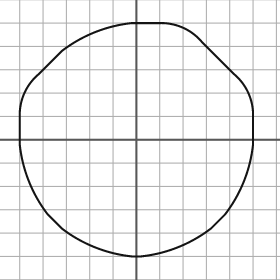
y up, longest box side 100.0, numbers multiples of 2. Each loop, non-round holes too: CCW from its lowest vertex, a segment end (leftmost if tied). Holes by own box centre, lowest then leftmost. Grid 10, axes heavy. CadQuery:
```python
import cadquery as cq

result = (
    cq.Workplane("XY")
    .moveTo(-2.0, -50.0)
    .lineTo(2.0, -50.0)
    .threePointArc((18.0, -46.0), (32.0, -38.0))
    .lineTo(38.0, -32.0)
    .threePointArc((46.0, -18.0), (50.0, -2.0))
    .lineTo(50.0, 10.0)
    .threePointArc((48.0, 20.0), (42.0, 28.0))
    .lineTo(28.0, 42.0)
    .threePointArc((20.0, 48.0), (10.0, 50.0))
    .lineTo(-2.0, 50.0)
    .threePointArc((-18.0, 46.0), (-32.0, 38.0))
    .lineTo(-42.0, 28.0)
    .threePointArc((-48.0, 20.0), (-50.0, 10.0))
    .lineTo(-50.0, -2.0)
    .threePointArc((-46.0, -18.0), (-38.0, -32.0))
    .lineTo(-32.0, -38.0)
    .threePointArc((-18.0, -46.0), (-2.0, -50.0))
    .close()
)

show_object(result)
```